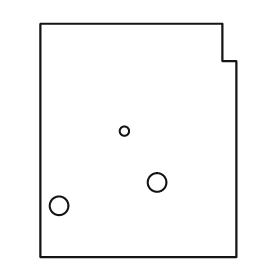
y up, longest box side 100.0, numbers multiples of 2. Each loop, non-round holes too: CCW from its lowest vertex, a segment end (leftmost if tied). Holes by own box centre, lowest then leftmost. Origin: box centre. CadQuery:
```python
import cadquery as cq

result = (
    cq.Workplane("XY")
    .moveTo(-42.0, -50.0)
    .lineTo(42.0, -50.0)
    .lineTo(42.0, 34.0)
    .lineTo(36.0, 34.0)
    .lineTo(36.0, 50.0)
    .lineTo(-42.0, 50.0)
    .close()
    .moveTo(-34.0, -28.0)
    .circle(4.0)
    .moveTo(8.0, -18.0)
    .circle(4.0)
    .moveTo(-6.0, 4.0)
    .circle(2.0)
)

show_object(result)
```